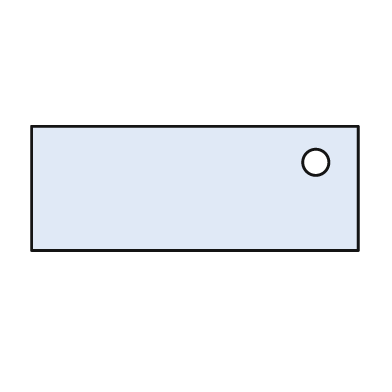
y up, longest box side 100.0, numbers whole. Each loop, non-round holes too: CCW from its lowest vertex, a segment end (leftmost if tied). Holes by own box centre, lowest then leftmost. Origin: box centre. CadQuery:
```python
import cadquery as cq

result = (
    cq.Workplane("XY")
    .moveTo(-50.0, -19.0)
    .lineTo(50.0, -19.0)
    .lineTo(50.0, 19.0)
    .lineTo(-50.0, 19.0)
    .close()
    .moveTo(37.0, 8.0)
    .circle(4.0)
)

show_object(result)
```